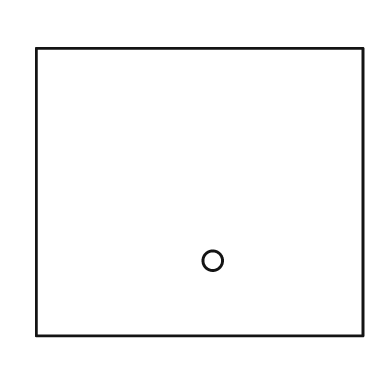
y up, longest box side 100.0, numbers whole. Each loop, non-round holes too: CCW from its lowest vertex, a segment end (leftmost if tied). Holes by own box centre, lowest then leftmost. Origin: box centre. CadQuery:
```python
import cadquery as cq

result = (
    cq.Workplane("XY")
    .moveTo(-50.0, -44.0)
    .lineTo(50.0, -44.0)
    .lineTo(50.0, 44.0)
    .lineTo(-50.0, 44.0)
    .close()
    .moveTo(4.0, -21.0)
    .circle(3.0)
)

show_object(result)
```